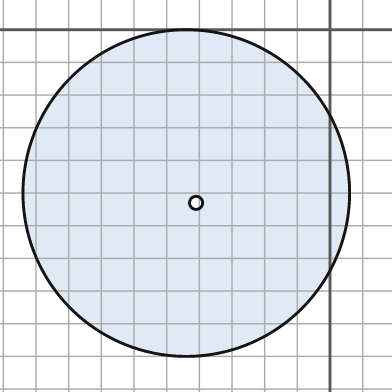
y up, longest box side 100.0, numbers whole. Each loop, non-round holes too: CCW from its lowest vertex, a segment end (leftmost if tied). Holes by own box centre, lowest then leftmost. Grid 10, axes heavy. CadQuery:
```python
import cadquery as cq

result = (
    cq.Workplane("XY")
    .moveTo(-44.0, -50.0)
    .circle(50.0)
    .moveTo(-41.0, -53.0)
    .circle(2.0)
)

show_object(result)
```